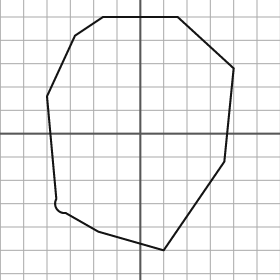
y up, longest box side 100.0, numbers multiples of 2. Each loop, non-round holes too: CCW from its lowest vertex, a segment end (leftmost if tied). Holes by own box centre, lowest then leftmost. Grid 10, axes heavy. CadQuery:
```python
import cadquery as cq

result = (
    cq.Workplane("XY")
    .moveTo(10.0, -50.0)
    .lineTo(36.0, -12.0)
    .lineTo(40.0, 28.0)
    .lineTo(16.0, 50.0)
    .lineTo(-16.0, 50.0)
    .lineTo(-28.0, 42.0)
    .lineTo(-40.0, 16.0)
    .lineTo(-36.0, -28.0)
    .threePointArc((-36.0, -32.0), (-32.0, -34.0))
    .lineTo(-18.0, -42.0)
    .close()
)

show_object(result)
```